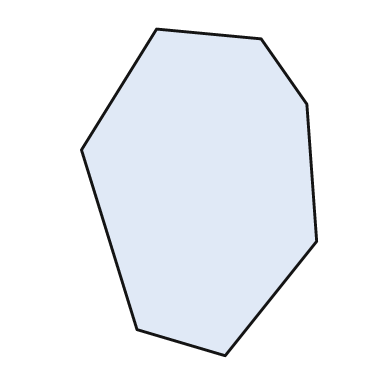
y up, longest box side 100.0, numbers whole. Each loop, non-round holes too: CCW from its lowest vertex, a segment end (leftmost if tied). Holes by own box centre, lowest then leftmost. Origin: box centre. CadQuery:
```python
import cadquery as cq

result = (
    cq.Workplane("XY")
    .moveTo(8.0, -50.0)
    .lineTo(36.0, -15.0)
    .lineTo(33.0, 27.0)
    .lineTo(19.0, 47.0)
    .lineTo(-13.0, 50.0)
    .lineTo(-36.0, 13.0)
    .lineTo(-19.0, -42.0)
    .close()
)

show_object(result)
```